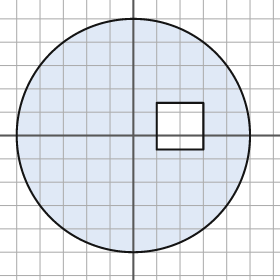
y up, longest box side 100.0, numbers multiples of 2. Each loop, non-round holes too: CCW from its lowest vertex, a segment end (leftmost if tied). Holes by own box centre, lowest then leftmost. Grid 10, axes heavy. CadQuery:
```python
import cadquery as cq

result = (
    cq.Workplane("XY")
    .moveTo(0.0, 0.0)
    .circle(50.0)
    .moveTo(10.0, -6.0)
    .lineTo(30.0, -6.0)
    .lineTo(30.0, 14.0)
    .lineTo(10.0, 14.0)
    .close()
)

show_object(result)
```